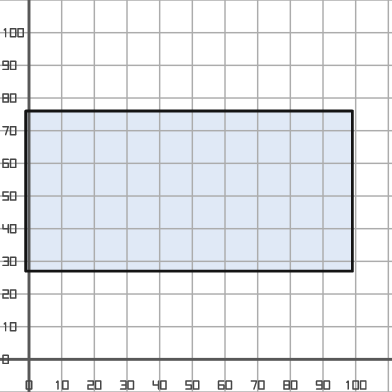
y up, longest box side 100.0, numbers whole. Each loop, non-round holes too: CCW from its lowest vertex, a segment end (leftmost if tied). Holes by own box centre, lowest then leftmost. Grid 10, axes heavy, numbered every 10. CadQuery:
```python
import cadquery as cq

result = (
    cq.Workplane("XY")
    .moveTo(-1.0, 27.0)
    .lineTo(99.0, 27.0)
    .lineTo(99.0, 76.0)
    .lineTo(-1.0, 76.0)
    .close()
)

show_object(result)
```